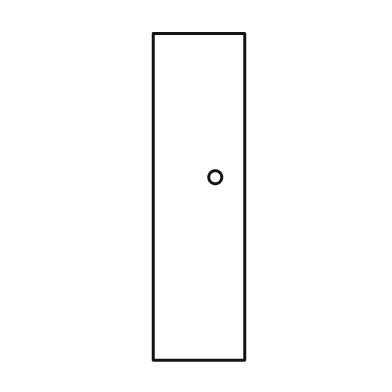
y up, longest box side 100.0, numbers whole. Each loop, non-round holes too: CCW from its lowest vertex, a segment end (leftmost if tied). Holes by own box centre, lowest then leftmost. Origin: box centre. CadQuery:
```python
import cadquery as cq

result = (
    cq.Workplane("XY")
    .moveTo(-14.0, -50.0)
    .lineTo(14.0, -50.0)
    .lineTo(14.0, 50.0)
    .lineTo(-14.0, 50.0)
    .close()
    .moveTo(5.0, 6.0)
    .circle(2.0)
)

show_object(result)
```